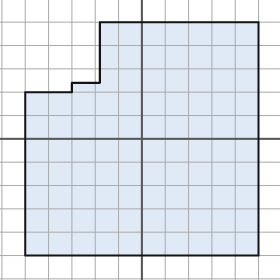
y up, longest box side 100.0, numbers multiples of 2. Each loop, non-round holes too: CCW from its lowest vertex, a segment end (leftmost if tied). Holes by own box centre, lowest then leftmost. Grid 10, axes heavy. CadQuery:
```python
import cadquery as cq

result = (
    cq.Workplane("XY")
    .moveTo(-50.0, -50.0)
    .lineTo(50.0, -50.0)
    .lineTo(50.0, 50.0)
    .lineTo(-18.0, 50.0)
    .lineTo(-18.0, 24.0)
    .lineTo(-30.0, 24.0)
    .lineTo(-30.0, 20.0)
    .lineTo(-50.0, 20.0)
    .close()
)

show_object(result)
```